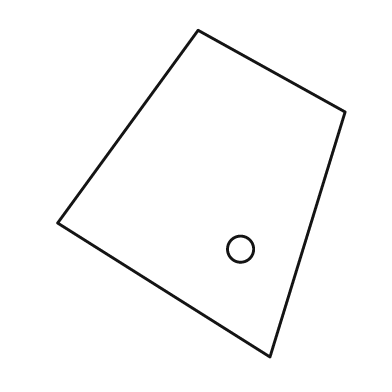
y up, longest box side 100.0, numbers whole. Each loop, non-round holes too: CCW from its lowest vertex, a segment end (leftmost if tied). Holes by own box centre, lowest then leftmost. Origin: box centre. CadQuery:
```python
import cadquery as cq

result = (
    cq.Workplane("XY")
    .moveTo(21.0, -50.0)
    .lineTo(44.0, 25.0)
    .lineTo(-1.0, 50.0)
    .lineTo(-44.0, -9.0)
    .close()
    .moveTo(12.0, -17.0)
    .circle(4.0)
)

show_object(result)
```